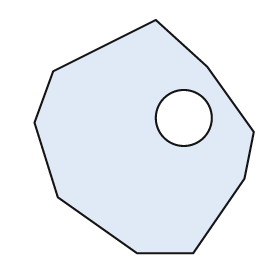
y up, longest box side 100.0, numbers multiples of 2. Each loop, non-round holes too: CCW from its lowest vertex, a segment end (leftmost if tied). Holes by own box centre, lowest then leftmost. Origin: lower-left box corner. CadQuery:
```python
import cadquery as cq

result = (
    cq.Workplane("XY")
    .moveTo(44.0, 0.0)
    .lineTo(68.0, 0.0)
    .lineTo(90.0, 32.0)
    .lineTo(94.0, 52.0)
    .lineTo(74.0, 80.0)
    .lineTo(52.0, 100.0)
    .lineTo(8.0, 78.0)
    .lineTo(0.0, 56.0)
    .lineTo(10.0, 24.0)
    .close()
    .moveTo(64.0, 58.0)
    .circle(12.0)
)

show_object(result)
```